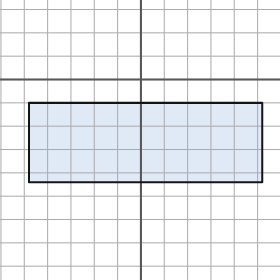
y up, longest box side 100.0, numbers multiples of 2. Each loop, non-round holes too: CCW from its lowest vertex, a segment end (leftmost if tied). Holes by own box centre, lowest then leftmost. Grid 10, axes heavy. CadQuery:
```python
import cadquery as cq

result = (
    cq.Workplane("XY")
    .moveTo(-48.0, -44.0)
    .lineTo(52.0, -44.0)
    .lineTo(52.0, -10.0)
    .lineTo(-48.0, -10.0)
    .close()
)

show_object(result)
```